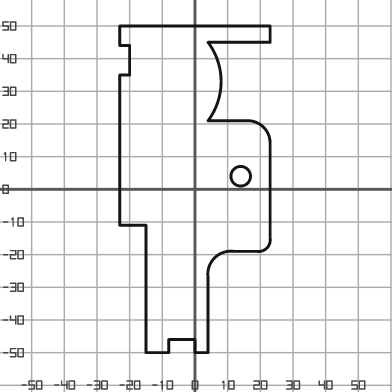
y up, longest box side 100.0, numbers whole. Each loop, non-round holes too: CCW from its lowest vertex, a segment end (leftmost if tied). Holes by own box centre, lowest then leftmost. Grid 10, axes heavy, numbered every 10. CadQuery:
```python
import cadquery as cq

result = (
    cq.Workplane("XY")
    .moveTo(-15.0, -50.0)
    .lineTo(-8.0, -50.0)
    .lineTo(-8.0, -46.0)
    .lineTo(0.0, -46.0)
    .lineTo(0.0, -50.0)
    .lineTo(4.0, -50.0)
    .lineTo(4.0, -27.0)
    .threePointArc((6.0, -21.0), (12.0, -19.0))
    .lineTo(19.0, -19.0)
    .threePointArc((22.0, -18.0), (23.0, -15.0))
    .lineTo(23.0, 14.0)
    .threePointArc((21.0, 19.0), (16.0, 21.0))
    .lineTo(4.0, 21.0)
    .threePointArc((8.0, 33.0), (4.0, 45.0))
    .lineTo(23.0, 45.0)
    .lineTo(23.0, 50.0)
    .lineTo(-23.0, 50.0)
    .lineTo(-23.0, 44.0)
    .lineTo(-20.0, 44.0)
    .lineTo(-20.0, 35.0)
    .lineTo(-23.0, 35.0)
    .lineTo(-23.0, -11.0)
    .lineTo(-15.0, -11.0)
    .close()
    .moveTo(14.0, 4.0)
    .circle(3.0)
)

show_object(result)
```